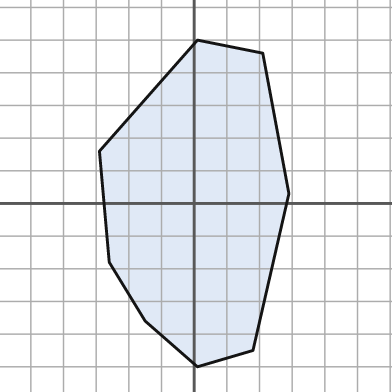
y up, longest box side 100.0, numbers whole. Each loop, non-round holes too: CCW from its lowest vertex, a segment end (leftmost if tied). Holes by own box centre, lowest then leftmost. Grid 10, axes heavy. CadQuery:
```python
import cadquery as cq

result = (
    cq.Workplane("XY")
    .moveTo(1.0, -50.0)
    .lineTo(18.0, -45.0)
    .lineTo(29.0, 3.0)
    .lineTo(21.0, 46.0)
    .lineTo(1.0, 50.0)
    .lineTo(-29.0, 16.0)
    .lineTo(-26.0, -18.0)
    .lineTo(-15.0, -36.0)
    .close()
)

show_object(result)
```